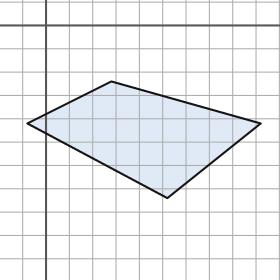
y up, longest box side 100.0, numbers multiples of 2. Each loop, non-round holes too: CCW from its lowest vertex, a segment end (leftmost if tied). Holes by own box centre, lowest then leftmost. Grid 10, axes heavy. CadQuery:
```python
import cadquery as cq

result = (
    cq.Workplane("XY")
    .moveTo(52.0, -74.0)
    .lineTo(92.0, -42.0)
    .lineTo(28.0, -24.0)
    .lineTo(-8.0, -42.0)
    .close()
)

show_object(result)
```